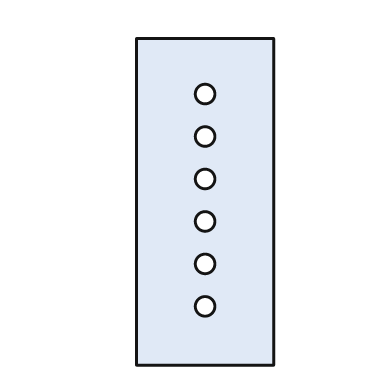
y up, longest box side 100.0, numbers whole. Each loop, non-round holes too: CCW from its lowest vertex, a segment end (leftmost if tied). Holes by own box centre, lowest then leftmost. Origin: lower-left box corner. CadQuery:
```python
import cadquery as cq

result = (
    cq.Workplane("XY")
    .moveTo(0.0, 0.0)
    .lineTo(42.0, 0.0)
    .lineTo(42.0, 100.0)
    .lineTo(0.0, 100.0)
    .close()
    .moveTo(21.0, 18.0)
    .circle(3.0)
    .moveTo(21.0, 31.0)
    .circle(3.0)
    .moveTo(21.0, 44.0)
    .circle(3.0)
    .moveTo(21.0, 57.0)
    .circle(3.0)
    .moveTo(21.0, 70.0)
    .circle(3.0)
    .moveTo(21.0, 83.0)
    .circle(3.0)
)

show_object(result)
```